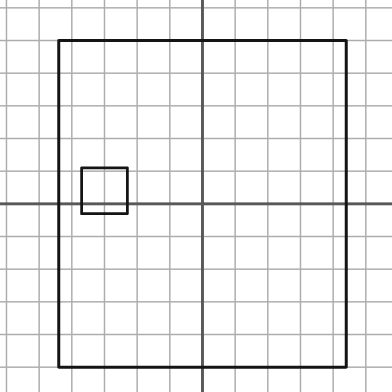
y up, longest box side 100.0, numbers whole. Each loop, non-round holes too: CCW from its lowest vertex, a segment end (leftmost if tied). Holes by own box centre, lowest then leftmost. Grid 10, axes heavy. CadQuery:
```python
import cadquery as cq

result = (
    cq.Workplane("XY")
    .moveTo(-44.0, -50.0)
    .lineTo(44.0, -50.0)
    .lineTo(44.0, 50.0)
    .lineTo(-44.0, 50.0)
    .close()
    .moveTo(-37.0, -3.0)
    .lineTo(-23.0, -3.0)
    .lineTo(-23.0, 11.0)
    .lineTo(-37.0, 11.0)
    .close()
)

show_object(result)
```